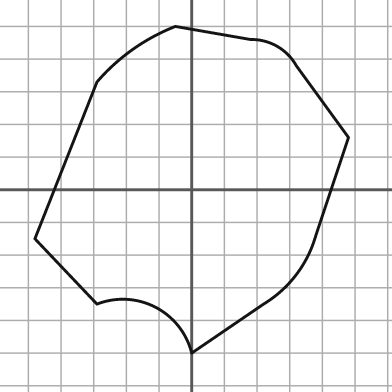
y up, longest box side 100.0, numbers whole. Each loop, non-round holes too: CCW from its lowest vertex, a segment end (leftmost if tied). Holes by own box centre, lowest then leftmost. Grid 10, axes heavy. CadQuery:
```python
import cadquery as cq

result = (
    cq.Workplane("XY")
    .moveTo(0.0, -50.0)
    .lineTo(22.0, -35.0)
    .threePointArc((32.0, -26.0), (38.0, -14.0))
    .lineTo(48.0, 16.0)
    .lineTo(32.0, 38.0)
    .threePointArc((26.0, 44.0), (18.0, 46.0))
    .lineTo(-5.0, 50.0)
    .threePointArc((-18.0, 43.0), (-29.0, 33.0))
    .lineTo(-48.0, -15.0)
    .lineTo(-29.0, -35.0)
    .threePointArc((-11.0, -36.0), (0.0, -50.0))
    .close()
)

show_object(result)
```